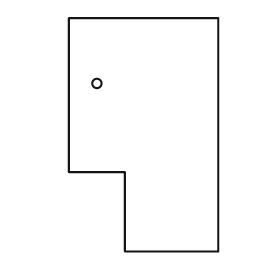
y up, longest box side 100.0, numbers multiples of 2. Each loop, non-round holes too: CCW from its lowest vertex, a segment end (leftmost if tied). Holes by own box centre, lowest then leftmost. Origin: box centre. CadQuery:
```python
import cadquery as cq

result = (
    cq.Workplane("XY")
    .moveTo(-8.0, -50.0)
    .lineTo(32.0, -50.0)
    .lineTo(32.0, 50.0)
    .lineTo(-32.0, 50.0)
    .lineTo(-32.0, -16.0)
    .lineTo(-8.0, -16.0)
    .close()
    .moveTo(-20.0, 22.0)
    .circle(2.0)
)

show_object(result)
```